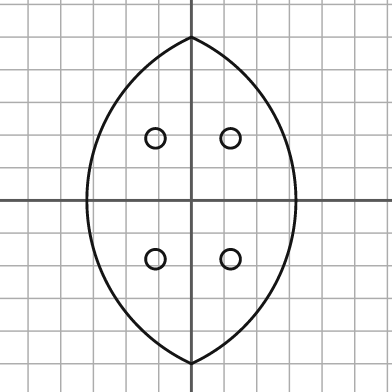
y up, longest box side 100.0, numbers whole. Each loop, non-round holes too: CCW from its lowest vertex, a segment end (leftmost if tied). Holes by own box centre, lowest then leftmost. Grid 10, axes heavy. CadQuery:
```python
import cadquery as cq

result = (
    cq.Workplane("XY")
    .moveTo(0.0, -50.0)
    .threePointArc((32.0, 0.0), (0.0, 50.0))
    .threePointArc((-32.0, 0.0), (0.0, -50.0))
    .close()
    .moveTo(-11.0, -18.0)
    .circle(3.0)
    .moveTo(12.0, -18.0)
    .circle(3.0)
    .moveTo(-11.0, 19.0)
    .circle(3.0)
    .moveTo(12.0, 19.0)
    .circle(3.0)
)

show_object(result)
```